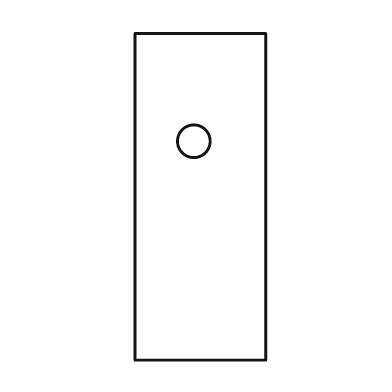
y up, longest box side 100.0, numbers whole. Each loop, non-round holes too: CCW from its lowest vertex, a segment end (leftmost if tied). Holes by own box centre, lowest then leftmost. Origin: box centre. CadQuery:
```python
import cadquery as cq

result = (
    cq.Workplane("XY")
    .moveTo(-20.0, -50.0)
    .lineTo(20.0, -50.0)
    .lineTo(20.0, 50.0)
    .lineTo(-20.0, 50.0)
    .close()
    .moveTo(-2.0, 17.0)
    .circle(5.0)
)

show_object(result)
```